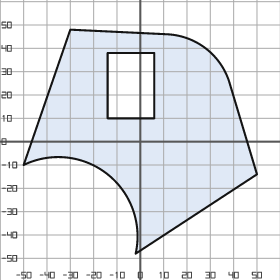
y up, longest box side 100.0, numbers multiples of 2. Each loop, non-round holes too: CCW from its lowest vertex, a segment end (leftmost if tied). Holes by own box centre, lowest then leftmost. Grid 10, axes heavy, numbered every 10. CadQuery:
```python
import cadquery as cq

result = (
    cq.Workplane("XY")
    .moveTo(-2.0, -48.0)
    .lineTo(50.0, -14.0)
    .lineTo(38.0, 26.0)
    .threePointArc((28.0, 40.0), (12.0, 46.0))
    .lineTo(-30.0, 48.0)
    .lineTo(-50.0, -10.0)
    .threePointArc((-14.0, -14.0), (-2.0, -48.0))
    .close()
    .moveTo(-14.0, 10.0)
    .lineTo(6.0, 10.0)
    .lineTo(6.0, 38.0)
    .lineTo(-14.0, 38.0)
    .close()
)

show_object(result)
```